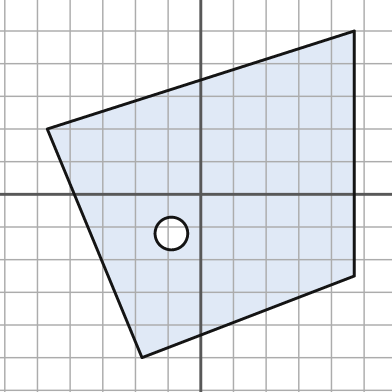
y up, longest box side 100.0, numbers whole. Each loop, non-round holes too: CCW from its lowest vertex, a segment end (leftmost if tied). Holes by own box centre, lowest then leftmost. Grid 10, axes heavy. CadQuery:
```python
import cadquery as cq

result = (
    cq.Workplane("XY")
    .moveTo(-18.0, -50.0)
    .lineTo(47.0, -25.0)
    .lineTo(47.0, 50.0)
    .lineTo(-47.0, 20.0)
    .close()
    .moveTo(-9.0, -12.0)
    .circle(5.0)
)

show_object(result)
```